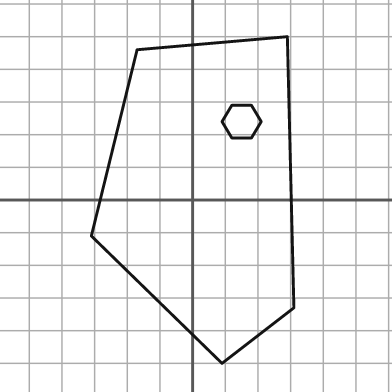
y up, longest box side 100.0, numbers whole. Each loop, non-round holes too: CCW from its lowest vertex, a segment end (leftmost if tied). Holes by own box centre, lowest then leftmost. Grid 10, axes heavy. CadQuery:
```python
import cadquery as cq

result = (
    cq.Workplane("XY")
    .moveTo(9.0, -50.0)
    .lineTo(31.0, -33.0)
    .lineTo(29.0, 50.0)
    .lineTo(-17.0, 46.0)
    .lineTo(-31.0, -11.0)
    .close()
    .moveTo(12.0, 19.0)
    .lineTo(18.0, 19.0)
    .lineTo(21.0, 24.0)
    .lineTo(18.0, 29.0)
    .lineTo(12.0, 29.0)
    .lineTo(9.0, 24.0)
    .close()
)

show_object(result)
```